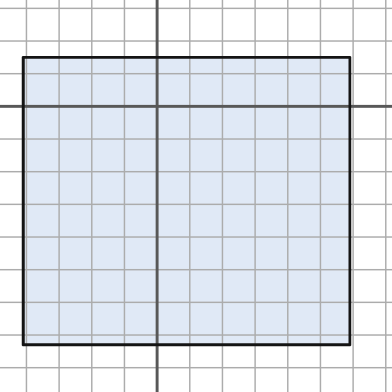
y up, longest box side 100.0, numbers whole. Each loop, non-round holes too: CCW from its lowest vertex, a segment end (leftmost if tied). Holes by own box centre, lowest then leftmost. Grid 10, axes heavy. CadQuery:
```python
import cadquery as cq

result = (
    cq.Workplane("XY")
    .moveTo(-41.0, -73.0)
    .lineTo(59.0, -73.0)
    .lineTo(59.0, 15.0)
    .lineTo(-41.0, 15.0)
    .close()
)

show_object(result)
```